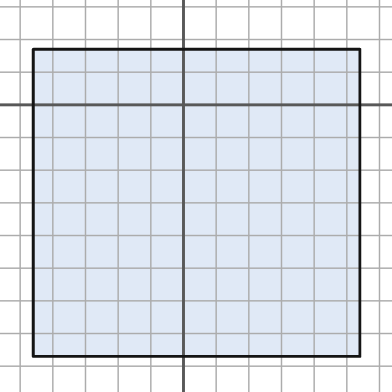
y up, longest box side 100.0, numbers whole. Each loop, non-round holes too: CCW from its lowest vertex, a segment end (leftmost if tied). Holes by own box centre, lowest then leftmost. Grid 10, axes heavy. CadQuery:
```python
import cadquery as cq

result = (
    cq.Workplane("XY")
    .moveTo(-46.0, -77.0)
    .lineTo(54.0, -77.0)
    .lineTo(54.0, 17.0)
    .lineTo(-46.0, 17.0)
    .close()
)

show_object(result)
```